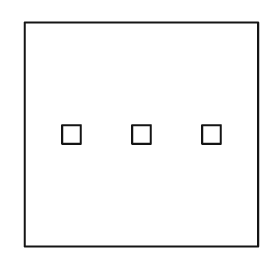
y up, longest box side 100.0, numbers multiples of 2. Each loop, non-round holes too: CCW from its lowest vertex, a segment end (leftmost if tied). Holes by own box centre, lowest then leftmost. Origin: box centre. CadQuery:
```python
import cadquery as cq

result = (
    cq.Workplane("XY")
    .moveTo(-50.0, -48.0)
    .lineTo(50.0, -48.0)
    .lineTo(50.0, 48.0)
    .lineTo(-50.0, 48.0)
    .close()
    .moveTo(-34.0, -4.0)
    .lineTo(-26.0, -4.0)
    .lineTo(-26.0, 4.0)
    .lineTo(-34.0, 4.0)
    .close()
    .moveTo(-4.0, -4.0)
    .lineTo(4.0, -4.0)
    .lineTo(4.0, 4.0)
    .lineTo(-4.0, 4.0)
    .close()
    .moveTo(26.0, -4.0)
    .lineTo(34.0, -4.0)
    .lineTo(34.0, 4.0)
    .lineTo(26.0, 4.0)
    .close()
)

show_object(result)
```